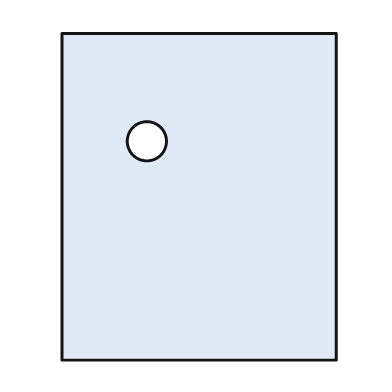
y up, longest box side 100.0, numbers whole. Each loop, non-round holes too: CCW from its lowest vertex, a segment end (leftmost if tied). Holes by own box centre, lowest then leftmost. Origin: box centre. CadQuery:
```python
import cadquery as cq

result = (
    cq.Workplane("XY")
    .moveTo(-42.0, -50.0)
    .lineTo(42.0, -50.0)
    .lineTo(42.0, 50.0)
    .lineTo(-42.0, 50.0)
    .close()
    .moveTo(-16.0, 17.0)
    .circle(6.0)
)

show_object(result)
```